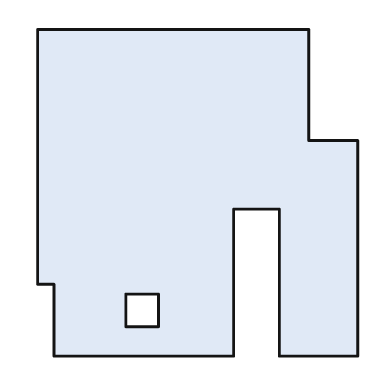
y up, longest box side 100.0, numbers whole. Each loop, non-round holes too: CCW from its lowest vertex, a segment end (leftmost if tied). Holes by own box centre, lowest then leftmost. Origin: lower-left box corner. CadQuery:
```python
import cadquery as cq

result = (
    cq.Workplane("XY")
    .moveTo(5.0, 0.0)
    .lineTo(60.0, 0.0)
    .lineTo(60.0, 45.0)
    .lineTo(74.0, 45.0)
    .lineTo(74.0, 0.0)
    .lineTo(98.0, 0.0)
    .lineTo(98.0, 66.0)
    .lineTo(83.0, 66.0)
    .lineTo(83.0, 100.0)
    .lineTo(0.0, 100.0)
    .lineTo(0.0, 22.0)
    .lineTo(5.0, 22.0)
    .close()
    .moveTo(27.0, 9.0)
    .lineTo(37.0, 9.0)
    .lineTo(37.0, 19.0)
    .lineTo(27.0, 19.0)
    .close()
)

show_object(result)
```